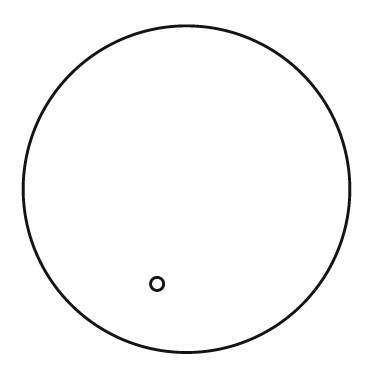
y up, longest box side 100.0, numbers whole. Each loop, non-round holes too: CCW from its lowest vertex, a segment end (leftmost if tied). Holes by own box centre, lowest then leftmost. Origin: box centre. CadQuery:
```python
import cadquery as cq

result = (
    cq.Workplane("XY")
    .moveTo(0.0, 0.0)
    .circle(50.0)
    .moveTo(-9.0, -29.0)
    .circle(2.0)
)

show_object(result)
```